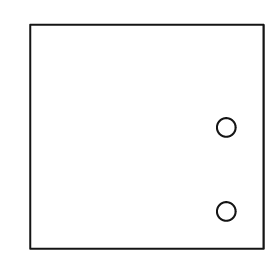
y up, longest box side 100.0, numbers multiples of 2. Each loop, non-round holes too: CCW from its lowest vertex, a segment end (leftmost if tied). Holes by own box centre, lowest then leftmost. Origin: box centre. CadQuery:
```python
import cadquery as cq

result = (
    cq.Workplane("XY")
    .moveTo(-50.0, -48.0)
    .lineTo(50.0, -48.0)
    .lineTo(50.0, 48.0)
    .lineTo(-50.0, 48.0)
    .close()
    .moveTo(34.0, -32.0)
    .circle(4.0)
    .moveTo(34.0, 4.0)
    .circle(4.0)
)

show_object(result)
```